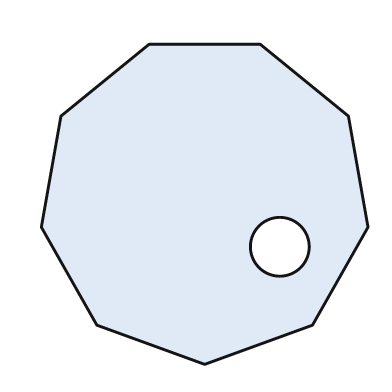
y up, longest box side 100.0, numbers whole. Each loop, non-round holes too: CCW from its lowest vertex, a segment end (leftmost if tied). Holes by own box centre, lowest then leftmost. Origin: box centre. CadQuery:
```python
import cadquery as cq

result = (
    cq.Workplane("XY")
    .moveTo(0.0, -49.0)
    .lineTo(33.0, -37.0)
    .lineTo(50.0, -7.0)
    .lineTo(44.0, 27.0)
    .lineTo(17.0, 49.0)
    .lineTo(-17.0, 49.0)
    .lineTo(-44.0, 27.0)
    .lineTo(-50.0, -7.0)
    .lineTo(-33.0, -37.0)
    .close()
    .moveTo(23.0, -13.0)
    .circle(9.0)
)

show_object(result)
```